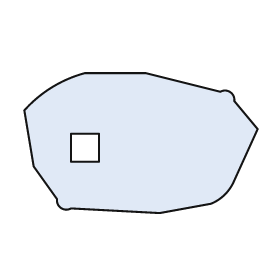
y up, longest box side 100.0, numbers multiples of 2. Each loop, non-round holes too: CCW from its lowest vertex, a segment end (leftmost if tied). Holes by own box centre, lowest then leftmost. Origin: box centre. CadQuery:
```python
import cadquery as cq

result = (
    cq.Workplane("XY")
    .moveTo(8.0, -30.0)
    .lineTo(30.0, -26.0)
    .threePointArc((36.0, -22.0), (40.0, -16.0))
    .lineTo(50.0, 6.0)
    .lineTo(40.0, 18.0)
    .threePointArc((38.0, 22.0), (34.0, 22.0))
    .lineTo(2.0, 30.0)
    .lineTo(-24.0, 30.0)
    .threePointArc((-38.0, 24.0), (-50.0, 14.0))
    .lineTo(-46.0, -10.0)
    .lineTo(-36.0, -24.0)
    .threePointArc((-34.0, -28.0), (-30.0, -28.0))
    .close()
    .moveTo(-30.0, -8.0)
    .lineTo(-18.0, -8.0)
    .lineTo(-18.0, 4.0)
    .lineTo(-30.0, 4.0)
    .close()
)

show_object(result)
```